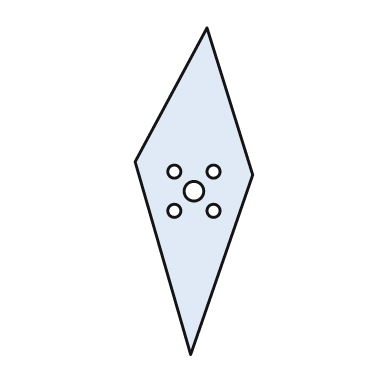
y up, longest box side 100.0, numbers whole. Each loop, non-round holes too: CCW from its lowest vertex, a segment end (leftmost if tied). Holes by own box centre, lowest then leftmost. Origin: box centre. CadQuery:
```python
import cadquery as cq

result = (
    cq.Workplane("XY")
    .moveTo(-1.0, -50.0)
    .lineTo(18.0, 5.0)
    .lineTo(4.0, 50.0)
    .lineTo(-18.0, 9.0)
    .close()
    .moveTo(-6.0, -6.0)
    .circle(2.0)
    .moveTo(6.0, -6.0)
    .circle(2.0)
    .moveTo(0.0, 0.0)
    .circle(3.0)
    .moveTo(-6.0, 6.0)
    .circle(2.0)
    .moveTo(6.0, 6.0)
    .circle(2.0)
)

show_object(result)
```